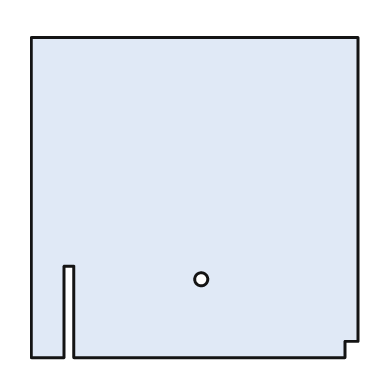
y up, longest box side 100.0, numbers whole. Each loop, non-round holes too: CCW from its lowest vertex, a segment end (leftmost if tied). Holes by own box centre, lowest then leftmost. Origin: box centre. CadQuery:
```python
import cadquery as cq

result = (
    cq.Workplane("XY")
    .moveTo(-50.0, -49.0)
    .lineTo(-40.0, -49.0)
    .lineTo(-40.0, -21.0)
    .lineTo(-37.0, -21.0)
    .lineTo(-37.0, -49.0)
    .lineTo(46.0, -49.0)
    .lineTo(46.0, -44.0)
    .lineTo(50.0, -44.0)
    .lineTo(50.0, 49.0)
    .lineTo(-50.0, 49.0)
    .close()
    .moveTo(2.0, -25.0)
    .circle(2.0)
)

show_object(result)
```